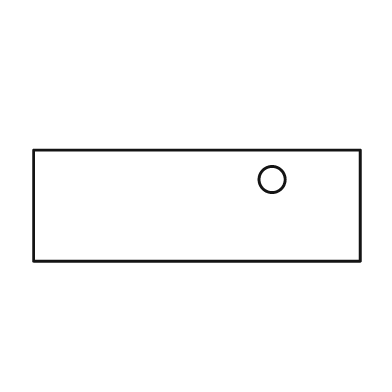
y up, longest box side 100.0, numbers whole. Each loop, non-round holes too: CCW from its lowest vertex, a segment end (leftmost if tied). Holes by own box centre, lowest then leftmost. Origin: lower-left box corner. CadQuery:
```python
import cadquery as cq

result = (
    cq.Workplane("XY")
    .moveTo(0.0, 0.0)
    .lineTo(100.0, 0.0)
    .lineTo(100.0, 34.0)
    .lineTo(0.0, 34.0)
    .close()
    .moveTo(73.0, 25.0)
    .circle(4.0)
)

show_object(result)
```